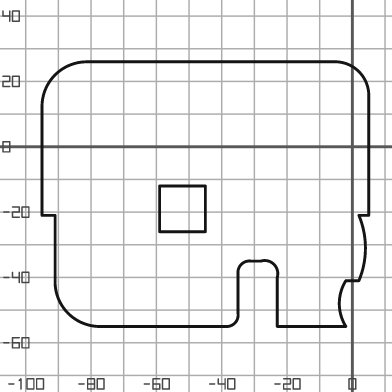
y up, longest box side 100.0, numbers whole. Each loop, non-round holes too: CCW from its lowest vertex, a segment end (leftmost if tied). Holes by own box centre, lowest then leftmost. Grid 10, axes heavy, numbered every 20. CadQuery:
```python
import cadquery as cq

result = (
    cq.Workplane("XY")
    .moveTo(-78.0, -55.0)
    .lineTo(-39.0, -55.0)
    .threePointArc((-36.0, -54.0), (-35.0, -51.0))
    .lineTo(-35.0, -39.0)
    .threePointArc((-34.0, -36.0), (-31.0, -35.0))
    .lineTo(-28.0, -35.0)
    .threePointArc((-24.0, -36.0), (-23.0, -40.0))
    .lineTo(-23.0, -55.0)
    .lineTo(-2.0, -55.0)
    .threePointArc((-4.0, -48.0), (-2.0, -41.0))
    .lineTo(2.0, -41.0)
    .threePointArc((4.0, -31.0), (2.0, -21.0))
    .lineTo(5.0, -21.0)
    .lineTo(5.0, 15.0)
    .threePointArc((2.0, 23.0), (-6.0, 26.0))
    .lineTo(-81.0, 26.0)
    .threePointArc((-91.0, 22.0), (-95.0, 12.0))
    .lineTo(-95.0, -21.0)
    .lineTo(-91.0, -21.0)
    .lineTo(-91.0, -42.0)
    .threePointArc((-87.0, -51.0), (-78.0, -55.0))
    .close()
    .moveTo(-59.0, -26.0)
    .lineTo(-45.0, -26.0)
    .lineTo(-45.0, -12.0)
    .lineTo(-59.0, -12.0)
    .close()
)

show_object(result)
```